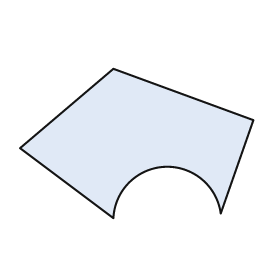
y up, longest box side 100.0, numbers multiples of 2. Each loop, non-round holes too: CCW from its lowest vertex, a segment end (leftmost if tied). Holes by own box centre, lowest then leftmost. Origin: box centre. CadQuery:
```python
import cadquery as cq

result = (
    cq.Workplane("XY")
    .moveTo(-10.0, -32.0)
    .threePointArc((12.0, -10.0), (36.0, -30.0))
    .lineTo(50.0, 10.0)
    .lineTo(-10.0, 32.0)
    .lineTo(-50.0, -2.0)
    .close()
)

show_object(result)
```